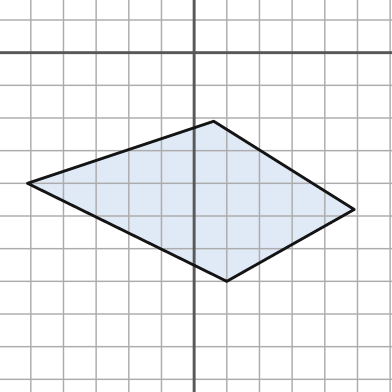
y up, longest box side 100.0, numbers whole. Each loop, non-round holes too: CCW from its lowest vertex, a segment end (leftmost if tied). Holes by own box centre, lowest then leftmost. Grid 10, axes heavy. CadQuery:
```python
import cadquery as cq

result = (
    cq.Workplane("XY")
    .moveTo(10.0, -70.0)
    .lineTo(49.0, -48.0)
    .lineTo(6.0, -21.0)
    .lineTo(-51.0, -40.0)
    .close()
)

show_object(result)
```